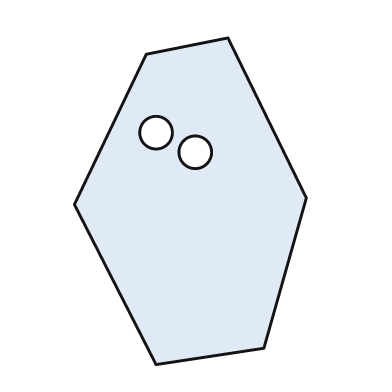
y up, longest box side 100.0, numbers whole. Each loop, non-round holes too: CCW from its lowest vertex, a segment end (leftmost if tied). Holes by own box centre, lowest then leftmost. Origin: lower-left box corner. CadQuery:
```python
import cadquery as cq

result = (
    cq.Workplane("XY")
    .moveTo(25.0, 0.0)
    .lineTo(58.0, 5.0)
    .lineTo(71.0, 51.0)
    .lineTo(47.0, 100.0)
    .lineTo(22.0, 95.0)
    .lineTo(0.0, 49.0)
    .close()
    .moveTo(37.0, 65.0)
    .circle(5.0)
    .moveTo(25.0, 71.0)
    .circle(5.0)
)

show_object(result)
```